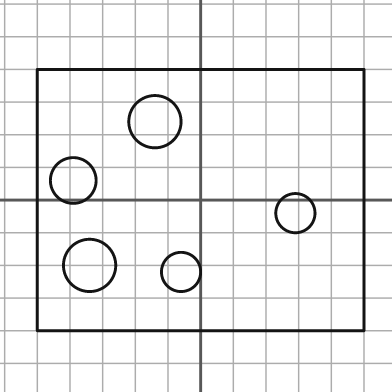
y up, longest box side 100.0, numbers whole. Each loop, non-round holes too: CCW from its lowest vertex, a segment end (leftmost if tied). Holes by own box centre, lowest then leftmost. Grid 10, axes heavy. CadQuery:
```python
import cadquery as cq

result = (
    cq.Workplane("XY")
    .moveTo(-50.0, -40.0)
    .lineTo(50.0, -40.0)
    .lineTo(50.0, 40.0)
    .lineTo(-50.0, 40.0)
    .close()
    .moveTo(-6.0, -22.0)
    .circle(6.0)
    .moveTo(-34.0, -20.0)
    .circle(8.0)
    .moveTo(29.0, -4.0)
    .circle(6.0)
    .moveTo(-39.0, 6.0)
    .circle(7.0)
    .moveTo(-14.0, 24.0)
    .circle(8.0)
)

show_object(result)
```